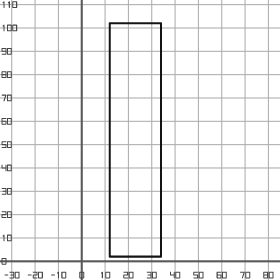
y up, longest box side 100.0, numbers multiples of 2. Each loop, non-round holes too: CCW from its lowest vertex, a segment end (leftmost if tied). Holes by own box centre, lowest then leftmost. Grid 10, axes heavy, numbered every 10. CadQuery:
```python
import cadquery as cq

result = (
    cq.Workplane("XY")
    .moveTo(12.0, 2.0)
    .lineTo(34.0, 2.0)
    .lineTo(34.0, 102.0)
    .lineTo(12.0, 102.0)
    .close()
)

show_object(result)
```